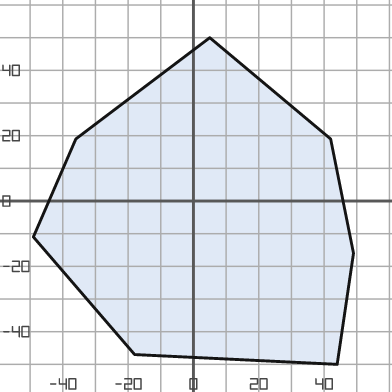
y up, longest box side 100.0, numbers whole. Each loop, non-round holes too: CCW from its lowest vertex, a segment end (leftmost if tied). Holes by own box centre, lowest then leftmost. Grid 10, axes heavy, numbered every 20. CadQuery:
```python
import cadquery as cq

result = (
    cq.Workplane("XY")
    .moveTo(44.0, -50.0)
    .lineTo(49.0, -16.0)
    .lineTo(42.0, 19.0)
    .lineTo(5.0, 50.0)
    .lineTo(-36.0, 19.0)
    .lineTo(-49.0, -11.0)
    .lineTo(-18.0, -47.0)
    .close()
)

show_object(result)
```